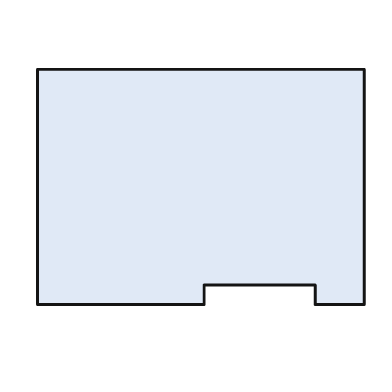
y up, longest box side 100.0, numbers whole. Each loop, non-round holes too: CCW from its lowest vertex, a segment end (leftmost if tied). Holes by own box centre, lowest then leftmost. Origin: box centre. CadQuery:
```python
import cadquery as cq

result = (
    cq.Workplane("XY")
    .moveTo(-50.0, -36.0)
    .lineTo(1.0, -36.0)
    .lineTo(1.0, -30.0)
    .lineTo(35.0, -30.0)
    .lineTo(35.0, -36.0)
    .lineTo(50.0, -36.0)
    .lineTo(50.0, 36.0)
    .lineTo(-50.0, 36.0)
    .close()
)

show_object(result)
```